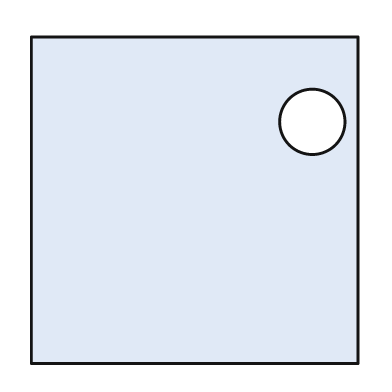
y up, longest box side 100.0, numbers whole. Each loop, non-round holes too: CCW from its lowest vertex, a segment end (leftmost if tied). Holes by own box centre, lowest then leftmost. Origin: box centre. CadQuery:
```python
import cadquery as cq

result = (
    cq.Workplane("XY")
    .moveTo(-50.0, -50.0)
    .lineTo(50.0, -50.0)
    .lineTo(50.0, 50.0)
    .lineTo(-50.0, 50.0)
    .close()
    .moveTo(36.0, 24.0)
    .circle(10.0)
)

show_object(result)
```